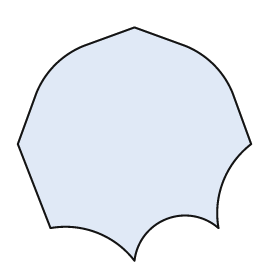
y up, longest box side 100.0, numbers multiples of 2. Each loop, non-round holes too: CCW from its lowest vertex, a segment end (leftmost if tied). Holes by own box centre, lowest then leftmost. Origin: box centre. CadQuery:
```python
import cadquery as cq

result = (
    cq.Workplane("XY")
    .moveTo(0.0, -50.0)
    .threePointArc((14.0, -32.0), (36.0, -36.0))
    .threePointArc((38.0, -16.0), (50.0, 0.0))
    .lineTo(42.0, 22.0)
    .threePointArc((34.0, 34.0), (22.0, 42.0))
    .lineTo(0.0, 50.0)
    .lineTo(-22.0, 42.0)
    .threePointArc((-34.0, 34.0), (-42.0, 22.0))
    .lineTo(-50.0, 0.0)
    .lineTo(-36.0, -36.0)
    .threePointArc((-16.0, -38.0), (0.0, -50.0))
    .close()
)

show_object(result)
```